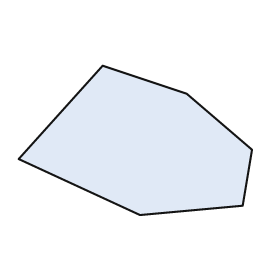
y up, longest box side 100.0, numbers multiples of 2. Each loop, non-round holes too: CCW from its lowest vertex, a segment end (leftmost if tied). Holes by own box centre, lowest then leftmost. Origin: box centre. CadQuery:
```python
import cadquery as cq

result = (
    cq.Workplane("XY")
    .moveTo(2.0, -32.0)
    .lineTo(46.0, -28.0)
    .lineTo(50.0, -4.0)
    .lineTo(22.0, 20.0)
    .lineTo(-14.0, 32.0)
    .lineTo(-50.0, -8.0)
    .close()
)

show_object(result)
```